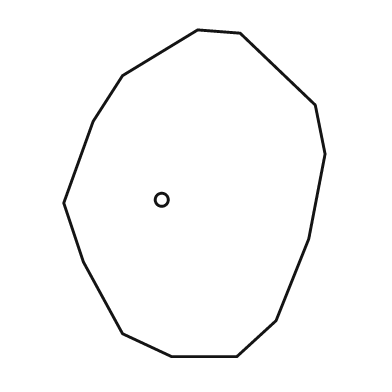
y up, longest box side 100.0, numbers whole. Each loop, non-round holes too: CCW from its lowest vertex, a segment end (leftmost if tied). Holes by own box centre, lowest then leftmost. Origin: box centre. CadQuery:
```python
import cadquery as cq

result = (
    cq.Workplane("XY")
    .moveTo(-7.0, -50.0)
    .lineTo(13.0, -50.0)
    .lineTo(25.0, -39.0)
    .lineTo(35.0, -14.0)
    .lineTo(40.0, 12.0)
    .lineTo(37.0, 27.0)
    .lineTo(14.0, 49.0)
    .lineTo(1.0, 50.0)
    .lineTo(-22.0, 36.0)
    .lineTo(-31.0, 22.0)
    .lineTo(-40.0, -3.0)
    .lineTo(-34.0, -21.0)
    .lineTo(-22.0, -43.0)
    .close()
    .moveTo(-10.0, -2.0)
    .circle(2.0)
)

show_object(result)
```